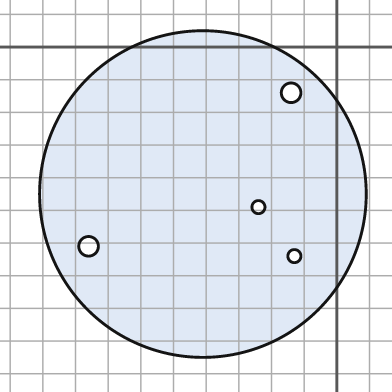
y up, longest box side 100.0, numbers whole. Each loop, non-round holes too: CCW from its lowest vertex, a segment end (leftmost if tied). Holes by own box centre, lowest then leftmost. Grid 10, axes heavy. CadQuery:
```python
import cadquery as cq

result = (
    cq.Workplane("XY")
    .moveTo(-41.0, -45.0)
    .circle(50.0)
    .moveTo(-13.0, -64.0)
    .circle(2.0)
    .moveTo(-76.0, -61.0)
    .circle(3.0)
    .moveTo(-24.0, -49.0)
    .circle(2.0)
    .moveTo(-14.0, -14.0)
    .circle(3.0)
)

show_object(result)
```